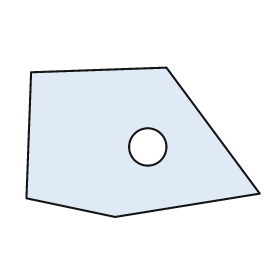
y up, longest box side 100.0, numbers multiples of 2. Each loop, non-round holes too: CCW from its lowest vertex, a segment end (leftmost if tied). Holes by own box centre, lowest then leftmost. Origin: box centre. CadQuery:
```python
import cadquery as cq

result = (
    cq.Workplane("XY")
    .moveTo(-12.0, -32.0)
    .lineTo(50.0, -22.0)
    .lineTo(10.0, 32.0)
    .lineTo(-48.0, 30.0)
    .lineTo(-50.0, -24.0)
    .close()
    .moveTo(2.0, -2.0)
    .circle(8.0)
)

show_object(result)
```